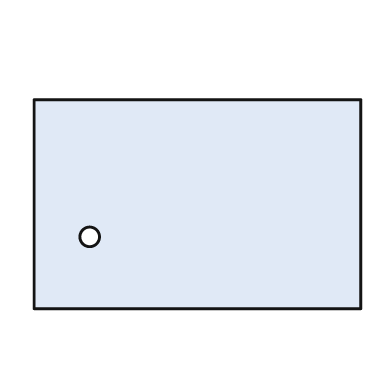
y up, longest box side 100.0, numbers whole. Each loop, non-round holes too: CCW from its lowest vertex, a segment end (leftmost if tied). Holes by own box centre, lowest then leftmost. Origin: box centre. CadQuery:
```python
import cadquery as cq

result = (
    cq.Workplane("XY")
    .moveTo(-50.0, -32.0)
    .lineTo(50.0, -32.0)
    .lineTo(50.0, 32.0)
    .lineTo(-50.0, 32.0)
    .close()
    .moveTo(-33.0, -10.0)
    .circle(3.0)
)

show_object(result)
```